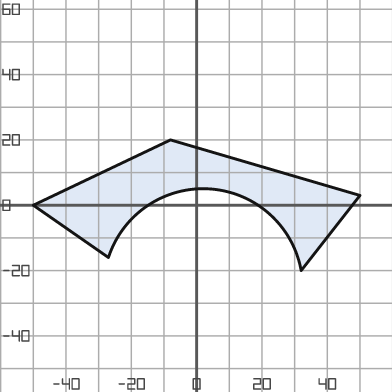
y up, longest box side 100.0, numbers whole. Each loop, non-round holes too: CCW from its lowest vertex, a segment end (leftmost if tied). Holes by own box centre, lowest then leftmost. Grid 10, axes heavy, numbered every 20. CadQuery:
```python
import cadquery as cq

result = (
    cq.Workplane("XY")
    .moveTo(32.0, -20.0)
    .lineTo(50.0, 3.0)
    .lineTo(-8.0, 20.0)
    .lineTo(-50.0, 0.0)
    .lineTo(-27.0, -16.0)
    .threePointArc((4.0, 5.0), (32.0, -20.0))
    .close()
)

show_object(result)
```